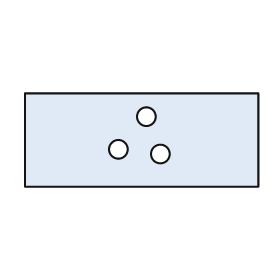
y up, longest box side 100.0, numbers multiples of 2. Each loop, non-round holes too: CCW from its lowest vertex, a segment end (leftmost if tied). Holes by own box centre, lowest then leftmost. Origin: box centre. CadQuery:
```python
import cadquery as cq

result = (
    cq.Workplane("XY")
    .moveTo(-50.0, -20.0)
    .lineTo(50.0, -20.0)
    .lineTo(50.0, 20.0)
    .lineTo(-50.0, 20.0)
    .close()
    .moveTo(8.0, -6.0)
    .circle(4.0)
    .moveTo(-10.0, -4.0)
    .circle(4.0)
    .moveTo(2.0, 10.0)
    .circle(4.0)
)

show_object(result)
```